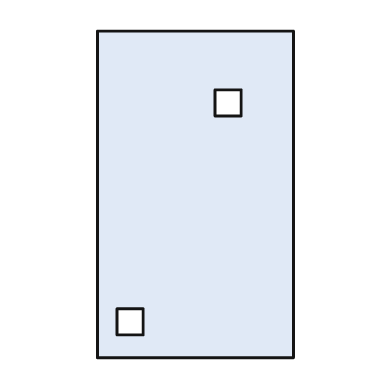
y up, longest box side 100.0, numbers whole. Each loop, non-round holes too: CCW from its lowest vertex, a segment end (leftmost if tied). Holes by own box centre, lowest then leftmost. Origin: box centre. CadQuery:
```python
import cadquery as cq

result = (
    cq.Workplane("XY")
    .moveTo(-30.0, -50.0)
    .lineTo(30.0, -50.0)
    .lineTo(30.0, 50.0)
    .lineTo(-30.0, 50.0)
    .close()
    .moveTo(-24.0, -43.0)
    .lineTo(-16.0, -43.0)
    .lineTo(-16.0, -35.0)
    .lineTo(-24.0, -35.0)
    .close()
    .moveTo(6.0, 24.0)
    .lineTo(14.0, 24.0)
    .lineTo(14.0, 32.0)
    .lineTo(6.0, 32.0)
    .close()
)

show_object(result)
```